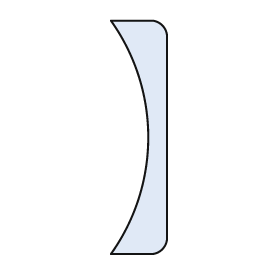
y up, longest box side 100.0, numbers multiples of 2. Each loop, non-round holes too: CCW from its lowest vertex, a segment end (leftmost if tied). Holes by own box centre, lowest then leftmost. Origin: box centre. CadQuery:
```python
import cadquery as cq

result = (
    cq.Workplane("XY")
    .moveTo(-12.0, -50.0)
    .lineTo(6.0, -50.0)
    .threePointArc((10.0, -48.0), (12.0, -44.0))
    .lineTo(12.0, 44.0)
    .threePointArc((10.0, 48.0), (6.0, 50.0))
    .lineTo(-12.0, 50.0)
    .threePointArc((4.0, 0.0), (-12.0, -50.0))
    .close()
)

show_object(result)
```